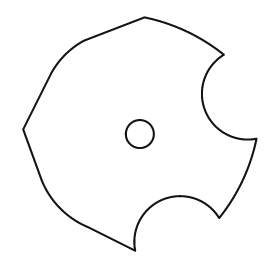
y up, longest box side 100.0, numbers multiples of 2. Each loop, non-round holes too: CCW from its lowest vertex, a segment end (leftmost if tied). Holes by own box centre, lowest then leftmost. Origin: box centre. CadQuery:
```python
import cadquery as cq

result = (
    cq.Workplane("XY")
    .moveTo(-2.0, -50.0)
    .threePointArc((10.0, -28.0), (34.0, -36.0))
    .threePointArc((44.0, -20.0), (50.0, -2.0))
    .threePointArc((28.0, 10.0), (36.0, 34.0))
    .threePointArc((20.0, 44.0), (2.0, 50.0))
    .lineTo(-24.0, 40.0)
    .threePointArc((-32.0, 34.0), (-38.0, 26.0))
    .lineTo(-50.0, 2.0)
    .lineTo(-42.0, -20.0)
    .threePointArc((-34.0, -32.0), (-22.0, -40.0))
    .close()
    .moveTo(0.0, 0.0)
    .circle(6.0)
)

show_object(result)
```